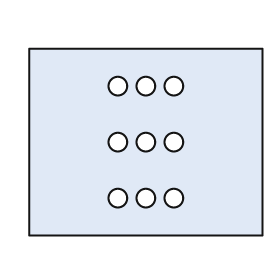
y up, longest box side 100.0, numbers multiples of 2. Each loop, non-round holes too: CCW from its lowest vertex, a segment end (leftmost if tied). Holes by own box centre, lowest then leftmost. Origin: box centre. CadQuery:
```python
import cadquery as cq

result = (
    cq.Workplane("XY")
    .moveTo(-50.0, -40.0)
    .lineTo(50.0, -40.0)
    .lineTo(50.0, 40.0)
    .lineTo(-50.0, 40.0)
    .close()
    .moveTo(-12.0, -24.0)
    .circle(4.0)
    .moveTo(0.0, -24.0)
    .circle(4.0)
    .moveTo(12.0, -24.0)
    .circle(4.0)
    .moveTo(-12.0, 0.0)
    .circle(4.0)
    .moveTo(0.0, 0.0)
    .circle(4.0)
    .moveTo(12.0, 0.0)
    .circle(4.0)
    .moveTo(-12.0, 24.0)
    .circle(4.0)
    .moveTo(0.0, 24.0)
    .circle(4.0)
    .moveTo(12.0, 24.0)
    .circle(4.0)
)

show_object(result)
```